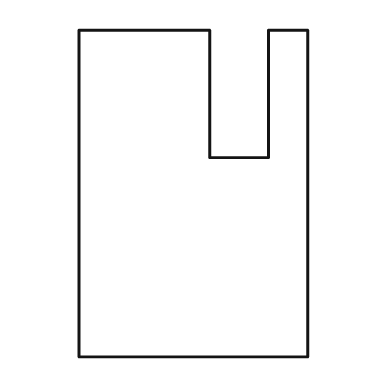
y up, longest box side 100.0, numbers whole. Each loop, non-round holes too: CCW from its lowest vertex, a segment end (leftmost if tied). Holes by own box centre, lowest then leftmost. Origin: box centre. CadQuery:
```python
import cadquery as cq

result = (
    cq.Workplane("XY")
    .moveTo(-35.0, -50.0)
    .lineTo(35.0, -50.0)
    .lineTo(35.0, 50.0)
    .lineTo(23.0, 50.0)
    .lineTo(23.0, 11.0)
    .lineTo(5.0, 11.0)
    .lineTo(5.0, 50.0)
    .lineTo(-35.0, 50.0)
    .close()
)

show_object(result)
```